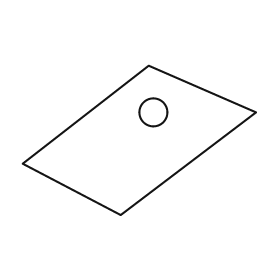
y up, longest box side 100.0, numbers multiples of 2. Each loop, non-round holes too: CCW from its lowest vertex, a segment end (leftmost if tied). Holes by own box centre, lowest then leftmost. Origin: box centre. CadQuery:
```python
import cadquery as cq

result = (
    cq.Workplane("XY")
    .moveTo(-8.0, -32.0)
    .lineTo(50.0, 12.0)
    .lineTo(4.0, 32.0)
    .lineTo(-50.0, -10.0)
    .close()
    .moveTo(6.0, 12.0)
    .circle(6.0)
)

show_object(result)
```